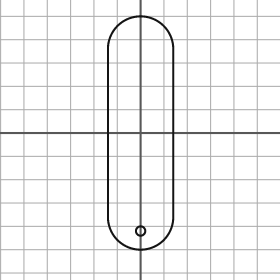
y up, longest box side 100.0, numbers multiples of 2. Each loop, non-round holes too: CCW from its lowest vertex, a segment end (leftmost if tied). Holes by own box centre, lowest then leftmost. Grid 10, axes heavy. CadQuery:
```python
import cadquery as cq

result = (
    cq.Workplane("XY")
    .moveTo(-14.0, -36.0)
    .threePointArc((0.0, -50.0), (14.0, -36.0))
    .lineTo(14.0, 36.0)
    .threePointArc((0.0, 50.0), (-14.0, 36.0))
    .close()
    .moveTo(0.0, -42.0)
    .circle(2.0)
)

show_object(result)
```